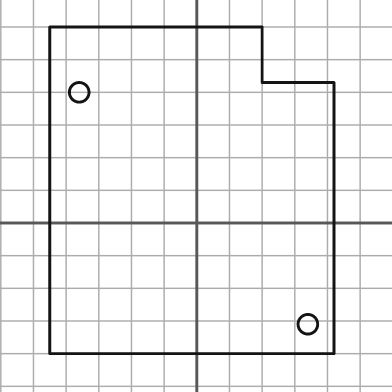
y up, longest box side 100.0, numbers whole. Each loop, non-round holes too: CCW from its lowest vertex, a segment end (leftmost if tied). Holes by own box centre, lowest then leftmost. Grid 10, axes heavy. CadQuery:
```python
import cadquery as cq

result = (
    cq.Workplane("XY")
    .moveTo(-45.0, -40.0)
    .lineTo(42.0, -40.0)
    .lineTo(42.0, 43.0)
    .lineTo(20.0, 43.0)
    .lineTo(20.0, 60.0)
    .lineTo(-45.0, 60.0)
    .close()
    .moveTo(34.0, -31.0)
    .circle(3.0)
    .moveTo(-36.0, 40.0)
    .circle(3.0)
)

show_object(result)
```